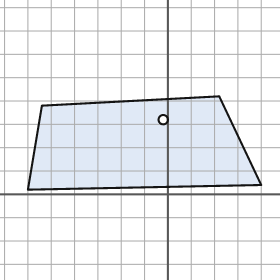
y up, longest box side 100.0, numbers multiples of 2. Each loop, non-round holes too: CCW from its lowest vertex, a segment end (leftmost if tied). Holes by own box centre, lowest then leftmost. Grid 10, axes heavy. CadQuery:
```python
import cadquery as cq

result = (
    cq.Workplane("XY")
    .moveTo(-60.0, 2.0)
    .lineTo(40.0, 4.0)
    .lineTo(22.0, 42.0)
    .lineTo(-54.0, 38.0)
    .close()
    .moveTo(-2.0, 32.0)
    .circle(2.0)
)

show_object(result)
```